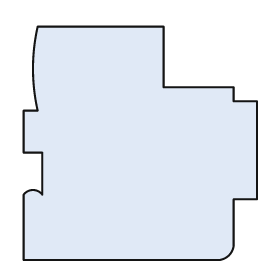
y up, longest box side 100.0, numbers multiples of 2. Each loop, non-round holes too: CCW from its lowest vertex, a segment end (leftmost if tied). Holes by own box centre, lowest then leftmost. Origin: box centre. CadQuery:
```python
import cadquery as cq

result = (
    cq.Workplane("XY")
    .moveTo(-50.0, -50.0)
    .lineTo(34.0, -50.0)
    .threePointArc((38.0, -48.0), (40.0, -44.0))
    .lineTo(40.0, -24.0)
    .lineTo(50.0, -24.0)
    .lineTo(50.0, 18.0)
    .lineTo(40.0, 18.0)
    .lineTo(40.0, 24.0)
    .lineTo(10.0, 24.0)
    .lineTo(10.0, 50.0)
    .lineTo(-44.0, 50.0)
    .threePointArc((-46.0, 32.0), (-44.0, 14.0))
    .lineTo(-50.0, 14.0)
    .lineTo(-50.0, -4.0)
    .lineTo(-42.0, -4.0)
    .lineTo(-42.0, -22.0)
    .threePointArc((-46.0, -20.0), (-50.0, -22.0))
    .close()
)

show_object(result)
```